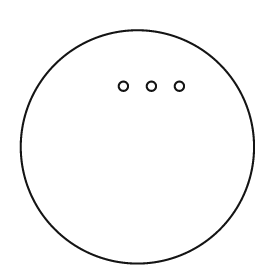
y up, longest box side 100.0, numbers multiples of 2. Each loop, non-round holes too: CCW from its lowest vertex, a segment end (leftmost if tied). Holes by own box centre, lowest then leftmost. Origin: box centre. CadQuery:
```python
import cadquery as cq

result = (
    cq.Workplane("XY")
    .moveTo(0.0, 0.0)
    .circle(50.0)
    .moveTo(-6.0, 26.0)
    .circle(2.0)
    .moveTo(6.0, 26.0)
    .circle(2.0)
    .moveTo(18.0, 26.0)
    .circle(2.0)
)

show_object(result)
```